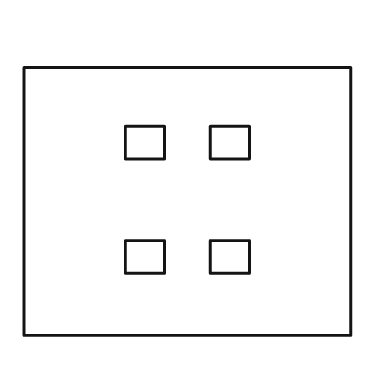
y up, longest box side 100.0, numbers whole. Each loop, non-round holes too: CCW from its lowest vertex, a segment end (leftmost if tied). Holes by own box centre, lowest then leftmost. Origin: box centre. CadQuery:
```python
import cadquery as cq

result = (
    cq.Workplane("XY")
    .moveTo(-50.0, -41.0)
    .lineTo(50.0, -41.0)
    .lineTo(50.0, 41.0)
    .lineTo(-50.0, 41.0)
    .close()
    .moveTo(-19.0, -22.0)
    .lineTo(-7.0, -22.0)
    .lineTo(-7.0, -12.0)
    .lineTo(-19.0, -12.0)
    .close()
    .moveTo(7.0, -22.0)
    .lineTo(19.0, -22.0)
    .lineTo(19.0, -12.0)
    .lineTo(7.0, -12.0)
    .close()
    .moveTo(-19.0, 13.0)
    .lineTo(-7.0, 13.0)
    .lineTo(-7.0, 23.0)
    .lineTo(-19.0, 23.0)
    .close()
    .moveTo(7.0, 13.0)
    .lineTo(19.0, 13.0)
    .lineTo(19.0, 23.0)
    .lineTo(7.0, 23.0)
    .close()
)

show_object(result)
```